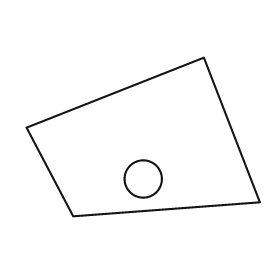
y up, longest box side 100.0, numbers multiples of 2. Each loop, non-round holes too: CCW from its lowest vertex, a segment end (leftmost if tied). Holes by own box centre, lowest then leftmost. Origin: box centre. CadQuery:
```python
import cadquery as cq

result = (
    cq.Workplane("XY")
    .moveTo(-30.0, -34.0)
    .lineTo(50.0, -28.0)
    .lineTo(26.0, 34.0)
    .lineTo(-50.0, 4.0)
    .close()
    .moveTo(0.0, -18.0)
    .circle(8.0)
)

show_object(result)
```